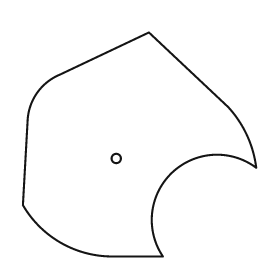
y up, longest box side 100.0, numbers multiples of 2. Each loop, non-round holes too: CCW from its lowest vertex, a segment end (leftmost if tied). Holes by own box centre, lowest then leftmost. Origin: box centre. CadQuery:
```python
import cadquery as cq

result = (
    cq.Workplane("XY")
    .moveTo(-12.0, -48.0)
    .lineTo(10.0, -48.0)
    .threePointArc((14.0, -12.0), (50.0, -10.0))
    .threePointArc((46.0, 4.0), (38.0, 16.0))
    .lineTo(4.0, 48.0)
    .lineTo(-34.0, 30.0)
    .threePointArc((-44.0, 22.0), (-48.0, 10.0))
    .lineTo(-50.0, -26.0)
    .threePointArc((-34.0, -42.0), (-12.0, -48.0))
    .close()
    .moveTo(-10.0, -6.0)
    .circle(2.0)
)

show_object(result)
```